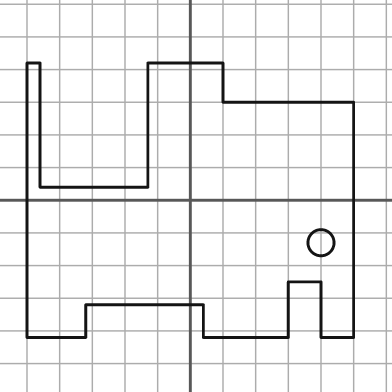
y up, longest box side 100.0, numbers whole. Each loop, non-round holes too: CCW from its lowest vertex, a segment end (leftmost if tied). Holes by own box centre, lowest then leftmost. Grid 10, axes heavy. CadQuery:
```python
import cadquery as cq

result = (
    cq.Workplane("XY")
    .moveTo(-50.0, -42.0)
    .lineTo(-32.0, -42.0)
    .lineTo(-32.0, -32.0)
    .lineTo(4.0, -32.0)
    .lineTo(4.0, -42.0)
    .lineTo(30.0, -42.0)
    .lineTo(30.0, -25.0)
    .lineTo(40.0, -25.0)
    .lineTo(40.0, -42.0)
    .lineTo(50.0, -42.0)
    .lineTo(50.0, 30.0)
    .lineTo(10.0, 30.0)
    .lineTo(10.0, 42.0)
    .lineTo(-13.0, 42.0)
    .lineTo(-13.0, 4.0)
    .lineTo(-46.0, 4.0)
    .lineTo(-46.0, 42.0)
    .lineTo(-50.0, 42.0)
    .close()
    .moveTo(40.0, -13.0)
    .circle(4.0)
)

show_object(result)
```